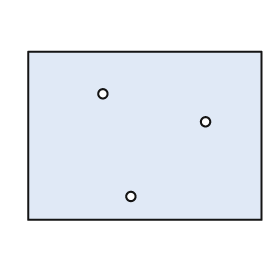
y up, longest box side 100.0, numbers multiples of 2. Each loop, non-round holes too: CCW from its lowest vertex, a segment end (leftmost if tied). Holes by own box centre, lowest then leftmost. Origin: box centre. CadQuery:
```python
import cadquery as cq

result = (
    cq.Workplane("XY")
    .moveTo(-50.0, -36.0)
    .lineTo(50.0, -36.0)
    .lineTo(50.0, 36.0)
    .lineTo(-50.0, 36.0)
    .close()
    .moveTo(-6.0, -26.0)
    .circle(2.0)
    .moveTo(26.0, 6.0)
    .circle(2.0)
    .moveTo(-18.0, 18.0)
    .circle(2.0)
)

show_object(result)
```